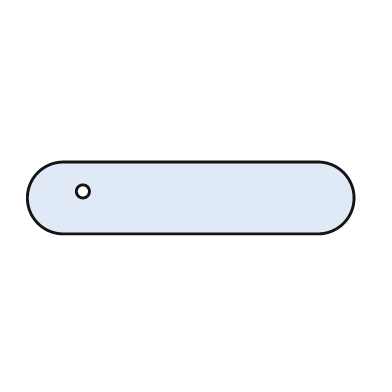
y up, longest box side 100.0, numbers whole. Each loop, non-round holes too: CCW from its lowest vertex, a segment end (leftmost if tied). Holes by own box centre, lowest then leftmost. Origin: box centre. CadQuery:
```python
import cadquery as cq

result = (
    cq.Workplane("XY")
    .moveTo(-39.0, -11.0)
    .lineTo(39.0, -11.0)
    .threePointArc((50.0, 0.0), (39.0, 11.0))
    .lineTo(-39.0, 11.0)
    .threePointArc((-50.0, 0.0), (-39.0, -11.0))
    .close()
    .moveTo(-33.0, 2.0)
    .circle(2.0)
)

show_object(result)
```